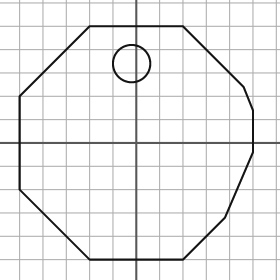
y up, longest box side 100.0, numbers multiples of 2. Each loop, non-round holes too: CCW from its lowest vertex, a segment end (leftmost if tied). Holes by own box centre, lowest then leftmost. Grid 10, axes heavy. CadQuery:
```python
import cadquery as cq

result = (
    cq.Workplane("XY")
    .moveTo(-20.0, -50.0)
    .lineTo(20.0, -50.0)
    .lineTo(38.0, -32.0)
    .lineTo(50.0, -4.0)
    .lineTo(50.0, 14.0)
    .lineTo(46.0, 24.0)
    .lineTo(20.0, 50.0)
    .lineTo(-20.0, 50.0)
    .lineTo(-50.0, 20.0)
    .lineTo(-50.0, -20.0)
    .close()
    .moveTo(-2.0, 34.0)
    .circle(8.0)
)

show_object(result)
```